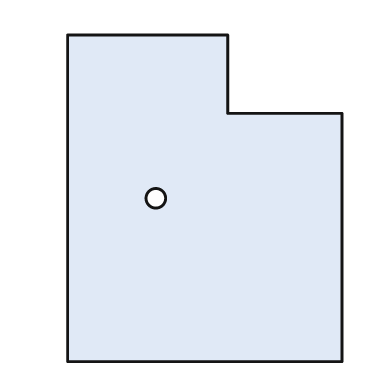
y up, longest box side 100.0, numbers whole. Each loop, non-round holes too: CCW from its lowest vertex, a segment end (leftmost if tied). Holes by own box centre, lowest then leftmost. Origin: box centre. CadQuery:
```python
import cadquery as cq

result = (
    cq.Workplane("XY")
    .moveTo(-42.0, -50.0)
    .lineTo(42.0, -50.0)
    .lineTo(42.0, 26.0)
    .lineTo(7.0, 26.0)
    .lineTo(7.0, 50.0)
    .lineTo(-42.0, 50.0)
    .close()
    .moveTo(-15.0, 0.0)
    .circle(3.0)
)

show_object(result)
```